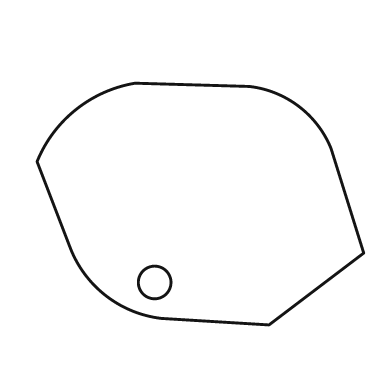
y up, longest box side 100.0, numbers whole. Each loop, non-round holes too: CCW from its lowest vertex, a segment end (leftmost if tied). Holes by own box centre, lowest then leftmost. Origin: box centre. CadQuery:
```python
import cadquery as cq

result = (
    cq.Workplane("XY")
    .moveTo(21.0, -37.0)
    .lineTo(50.0, -15.0)
    .lineTo(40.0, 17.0)
    .threePointArc((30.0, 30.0), (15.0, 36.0))
    .lineTo(-20.0, 37.0)
    .threePointArc((-38.0, 29.0), (-50.0, 13.0))
    .lineTo(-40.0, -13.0)
    .threePointArc((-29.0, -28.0), (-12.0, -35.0))
    .close()
    .moveTo(-14.0, -24.0)
    .circle(5.0)
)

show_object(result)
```